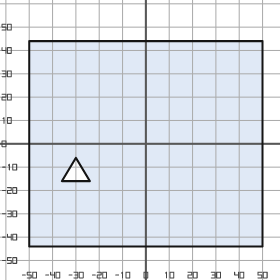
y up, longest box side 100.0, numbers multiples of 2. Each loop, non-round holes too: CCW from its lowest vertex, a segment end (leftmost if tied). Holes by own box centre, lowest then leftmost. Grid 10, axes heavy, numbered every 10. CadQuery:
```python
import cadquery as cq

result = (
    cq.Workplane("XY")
    .moveTo(-50.0, -44.0)
    .lineTo(50.0, -44.0)
    .lineTo(50.0, 44.0)
    .lineTo(-50.0, 44.0)
    .close()
    .moveTo(-36.0, -16.0)
    .lineTo(-24.0, -16.0)
    .lineTo(-30.0, -6.0)
    .close()
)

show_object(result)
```